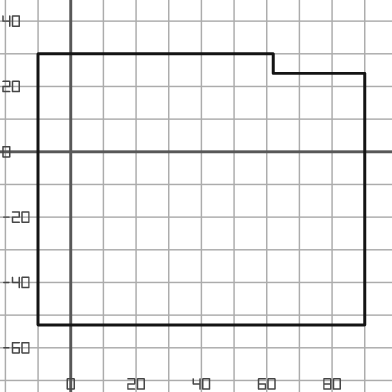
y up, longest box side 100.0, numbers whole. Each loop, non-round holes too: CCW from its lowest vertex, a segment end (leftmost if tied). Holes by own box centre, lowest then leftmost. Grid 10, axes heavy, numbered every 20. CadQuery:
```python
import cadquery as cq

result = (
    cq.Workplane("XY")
    .moveTo(-10.0, -53.0)
    .lineTo(90.0, -53.0)
    .lineTo(90.0, 24.0)
    .lineTo(62.0, 24.0)
    .lineTo(62.0, 30.0)
    .lineTo(-10.0, 30.0)
    .close()
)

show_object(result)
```